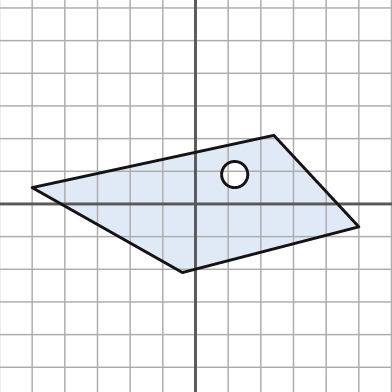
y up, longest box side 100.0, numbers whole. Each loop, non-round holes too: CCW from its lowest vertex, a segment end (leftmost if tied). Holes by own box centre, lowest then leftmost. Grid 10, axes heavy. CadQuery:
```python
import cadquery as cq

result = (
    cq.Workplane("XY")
    .moveTo(-4.0, -21.0)
    .lineTo(50.0, -7.0)
    .lineTo(24.0, 21.0)
    .lineTo(-50.0, 5.0)
    .close()
    .moveTo(12.0, 9.0)
    .circle(4.0)
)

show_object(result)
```